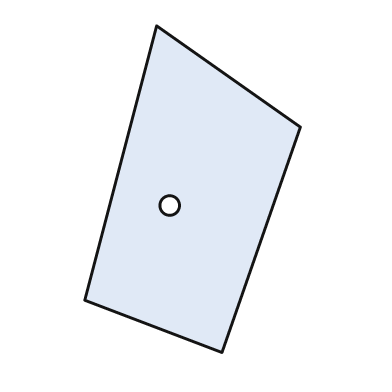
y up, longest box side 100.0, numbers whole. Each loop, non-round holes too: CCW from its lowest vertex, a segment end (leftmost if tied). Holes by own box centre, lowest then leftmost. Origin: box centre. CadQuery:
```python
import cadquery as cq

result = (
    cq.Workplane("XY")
    .moveTo(9.0, -50.0)
    .lineTo(33.0, 19.0)
    .lineTo(-11.0, 50.0)
    .lineTo(-33.0, -34.0)
    .close()
    .moveTo(-7.0, -5.0)
    .circle(3.0)
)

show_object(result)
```